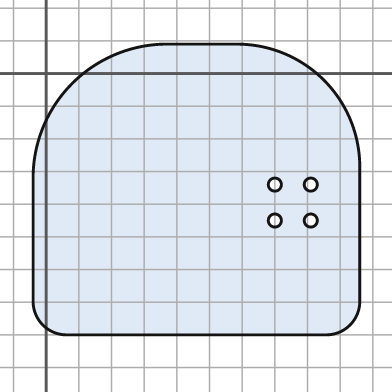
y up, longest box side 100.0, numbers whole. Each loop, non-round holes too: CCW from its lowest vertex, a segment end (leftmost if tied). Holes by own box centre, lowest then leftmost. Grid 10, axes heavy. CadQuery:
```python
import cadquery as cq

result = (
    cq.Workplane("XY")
    .moveTo(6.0, -80.0)
    .lineTo(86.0, -80.0)
    .threePointArc((93.0, -77.0), (96.0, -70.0))
    .lineTo(96.0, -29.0)
    .threePointArc((85.0, -2.0), (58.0, 9.0))
    .lineTo(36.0, 9.0)
    .threePointArc((8.0, -3.0), (-4.0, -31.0))
    .lineTo(-4.0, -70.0)
    .threePointArc((-1.0, -77.0), (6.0, -80.0))
    .close()
    .moveTo(70.0, -45.0)
    .circle(2.0)
    .moveTo(81.0, -45.0)
    .circle(2.0)
    .moveTo(70.0, -34.0)
    .circle(2.0)
    .moveTo(81.0, -34.0)
    .circle(2.0)
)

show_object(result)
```